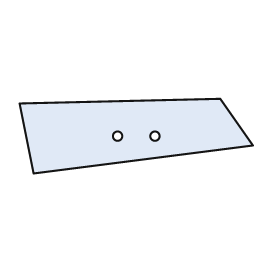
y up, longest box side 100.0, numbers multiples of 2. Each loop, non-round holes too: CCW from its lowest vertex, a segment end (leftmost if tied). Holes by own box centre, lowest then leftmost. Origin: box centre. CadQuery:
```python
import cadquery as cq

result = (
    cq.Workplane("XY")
    .moveTo(-44.0, -16.0)
    .lineTo(50.0, -4.0)
    .lineTo(36.0, 16.0)
    .lineTo(-50.0, 14.0)
    .close()
    .moveTo(-8.0, 0.0)
    .circle(2.0)
    .moveTo(8.0, 0.0)
    .circle(2.0)
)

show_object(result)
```